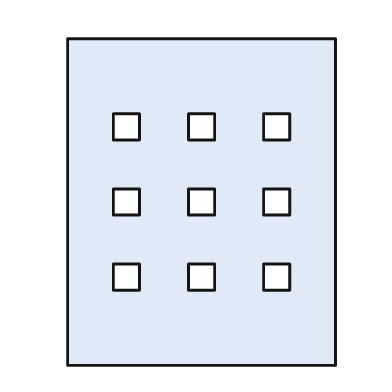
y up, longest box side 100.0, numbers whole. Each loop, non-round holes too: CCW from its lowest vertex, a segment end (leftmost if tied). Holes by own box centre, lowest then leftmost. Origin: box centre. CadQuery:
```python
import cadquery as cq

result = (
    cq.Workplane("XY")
    .moveTo(-41.0, -50.0)
    .lineTo(41.0, -50.0)
    .lineTo(41.0, 50.0)
    .lineTo(-41.0, 50.0)
    .close()
    .moveTo(-27.0, -27.0)
    .lineTo(-19.0, -27.0)
    .lineTo(-19.0, -19.0)
    .lineTo(-27.0, -19.0)
    .close()
    .moveTo(-4.0, -27.0)
    .lineTo(4.0, -27.0)
    .lineTo(4.0, -19.0)
    .lineTo(-4.0, -19.0)
    .close()
    .moveTo(19.0, -27.0)
    .lineTo(27.0, -27.0)
    .lineTo(27.0, -19.0)
    .lineTo(19.0, -19.0)
    .close()
    .moveTo(-27.0, -4.0)
    .lineTo(-19.0, -4.0)
    .lineTo(-19.0, 4.0)
    .lineTo(-27.0, 4.0)
    .close()
    .moveTo(-4.0, -4.0)
    .lineTo(4.0, -4.0)
    .lineTo(4.0, 4.0)
    .lineTo(-4.0, 4.0)
    .close()
    .moveTo(19.0, -4.0)
    .lineTo(27.0, -4.0)
    .lineTo(27.0, 4.0)
    .lineTo(19.0, 4.0)
    .close()
    .moveTo(-27.0, 19.0)
    .lineTo(-19.0, 19.0)
    .lineTo(-19.0, 27.0)
    .lineTo(-27.0, 27.0)
    .close()
    .moveTo(-4.0, 19.0)
    .lineTo(4.0, 19.0)
    .lineTo(4.0, 27.0)
    .lineTo(-4.0, 27.0)
    .close()
    .moveTo(19.0, 19.0)
    .lineTo(27.0, 19.0)
    .lineTo(27.0, 27.0)
    .lineTo(19.0, 27.0)
    .close()
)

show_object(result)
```